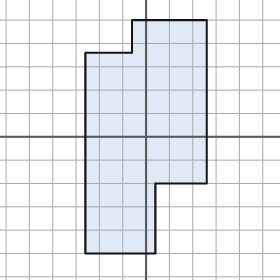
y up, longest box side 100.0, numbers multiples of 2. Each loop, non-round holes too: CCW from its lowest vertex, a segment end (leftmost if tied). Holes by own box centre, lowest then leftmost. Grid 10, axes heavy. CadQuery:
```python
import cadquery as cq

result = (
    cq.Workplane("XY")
    .moveTo(-26.0, -50.0)
    .lineTo(4.0, -50.0)
    .lineTo(4.0, -20.0)
    .lineTo(26.0, -20.0)
    .lineTo(26.0, 50.0)
    .lineTo(-6.0, 50.0)
    .lineTo(-6.0, 36.0)
    .lineTo(-26.0, 36.0)
    .close()
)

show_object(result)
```